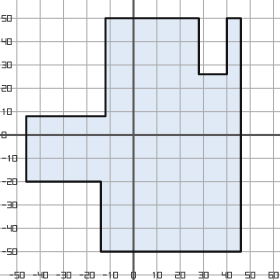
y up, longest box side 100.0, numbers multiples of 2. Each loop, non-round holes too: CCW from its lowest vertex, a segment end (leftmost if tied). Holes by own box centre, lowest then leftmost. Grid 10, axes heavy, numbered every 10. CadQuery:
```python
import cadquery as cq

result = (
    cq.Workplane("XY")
    .moveTo(-14.0, -50.0)
    .lineTo(46.0, -50.0)
    .lineTo(46.0, 50.0)
    .lineTo(40.0, 50.0)
    .lineTo(40.0, 26.0)
    .lineTo(28.0, 26.0)
    .lineTo(28.0, 50.0)
    .lineTo(-12.0, 50.0)
    .lineTo(-12.0, 8.0)
    .lineTo(-46.0, 8.0)
    .lineTo(-46.0, -20.0)
    .lineTo(-14.0, -20.0)
    .close()
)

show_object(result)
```